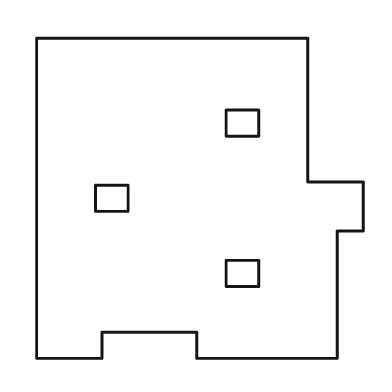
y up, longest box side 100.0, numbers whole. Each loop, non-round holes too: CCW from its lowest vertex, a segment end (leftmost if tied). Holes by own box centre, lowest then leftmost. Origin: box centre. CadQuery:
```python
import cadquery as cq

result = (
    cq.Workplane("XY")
    .moveTo(-50.0, -49.0)
    .lineTo(-30.0, -49.0)
    .lineTo(-30.0, -41.0)
    .lineTo(-1.0, -41.0)
    .lineTo(-1.0, -49.0)
    .lineTo(42.0, -49.0)
    .lineTo(42.0, -10.0)
    .lineTo(50.0, -10.0)
    .lineTo(50.0, 5.0)
    .lineTo(33.0, 5.0)
    .lineTo(33.0, 49.0)
    .lineTo(-50.0, 49.0)
    .close()
    .moveTo(8.0, -27.0)
    .lineTo(18.0, -27.0)
    .lineTo(18.0, -19.0)
    .lineTo(8.0, -19.0)
    .close()
    .moveTo(-32.0, -4.0)
    .lineTo(-22.0, -4.0)
    .lineTo(-22.0, 4.0)
    .lineTo(-32.0, 4.0)
    .close()
    .moveTo(8.0, 19.0)
    .lineTo(18.0, 19.0)
    .lineTo(18.0, 27.0)
    .lineTo(8.0, 27.0)
    .close()
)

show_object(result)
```